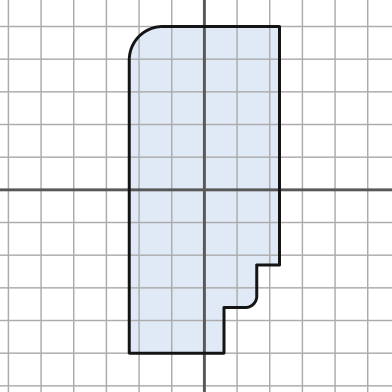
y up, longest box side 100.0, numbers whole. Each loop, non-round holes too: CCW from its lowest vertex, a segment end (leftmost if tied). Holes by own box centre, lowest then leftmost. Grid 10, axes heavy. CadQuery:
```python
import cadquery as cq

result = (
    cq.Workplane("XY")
    .moveTo(-23.0, -50.0)
    .lineTo(6.0, -50.0)
    .lineTo(6.0, -36.0)
    .lineTo(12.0, -36.0)
    .threePointArc((15.0, -35.0), (16.0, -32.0))
    .lineTo(16.0, -23.0)
    .lineTo(23.0, -23.0)
    .lineTo(23.0, 50.0)
    .lineTo(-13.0, 50.0)
    .threePointArc((-20.0, 47.0), (-23.0, 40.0))
    .close()
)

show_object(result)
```